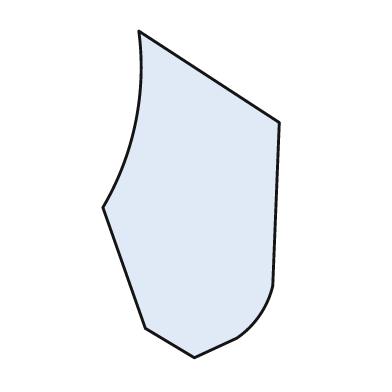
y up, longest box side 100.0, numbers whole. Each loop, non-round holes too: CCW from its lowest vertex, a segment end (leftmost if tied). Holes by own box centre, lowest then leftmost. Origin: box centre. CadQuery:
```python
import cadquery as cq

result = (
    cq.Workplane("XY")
    .moveTo(1.0, -50.0)
    .lineTo(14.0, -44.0)
    .threePointArc((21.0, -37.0), (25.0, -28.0))
    .lineTo(27.0, 22.0)
    .lineTo(-16.0, 50.0)
    .threePointArc((-17.0, 22.0), (-27.0, -4.0))
    .lineTo(-14.0, -41.0)
    .close()
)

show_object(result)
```